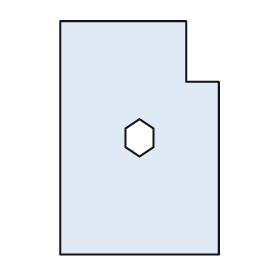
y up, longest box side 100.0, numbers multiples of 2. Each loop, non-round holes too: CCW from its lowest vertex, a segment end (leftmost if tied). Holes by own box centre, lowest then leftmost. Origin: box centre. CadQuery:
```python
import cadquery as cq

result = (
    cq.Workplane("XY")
    .moveTo(-34.0, -50.0)
    .lineTo(34.0, -50.0)
    .lineTo(34.0, 24.0)
    .lineTo(20.0, 24.0)
    .lineTo(20.0, 50.0)
    .lineTo(-34.0, 50.0)
    .close()
    .moveTo(0.0, -8.0)
    .lineTo(6.0, -4.0)
    .lineTo(6.0, 4.0)
    .lineTo(0.0, 8.0)
    .lineTo(-6.0, 4.0)
    .lineTo(-6.0, -4.0)
    .close()
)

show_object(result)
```